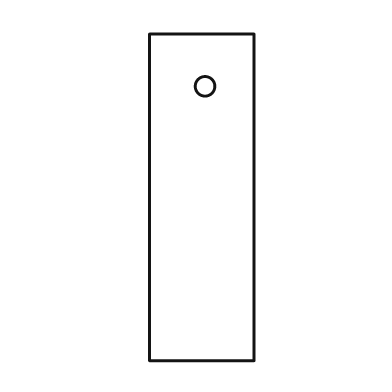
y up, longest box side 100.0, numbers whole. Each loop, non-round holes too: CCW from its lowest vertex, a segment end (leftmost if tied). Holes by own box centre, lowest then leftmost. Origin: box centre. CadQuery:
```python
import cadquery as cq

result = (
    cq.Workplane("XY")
    .moveTo(-16.0, -50.0)
    .lineTo(16.0, -50.0)
    .lineTo(16.0, 50.0)
    .lineTo(-16.0, 50.0)
    .close()
    .moveTo(1.0, 34.0)
    .circle(3.0)
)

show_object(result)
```